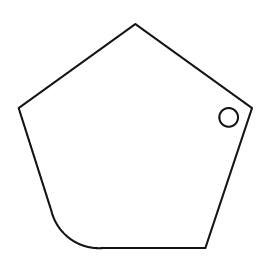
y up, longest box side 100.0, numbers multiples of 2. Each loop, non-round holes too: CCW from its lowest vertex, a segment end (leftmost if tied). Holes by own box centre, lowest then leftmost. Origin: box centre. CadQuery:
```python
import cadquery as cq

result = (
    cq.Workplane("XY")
    .moveTo(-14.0, -48.0)
    .lineTo(30.0, -48.0)
    .lineTo(50.0, 12.0)
    .lineTo(0.0, 48.0)
    .lineTo(-50.0, 12.0)
    .lineTo(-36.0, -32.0)
    .threePointArc((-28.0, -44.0), (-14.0, -48.0))
    .close()
    .moveTo(40.0, 8.0)
    .circle(4.0)
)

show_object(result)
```